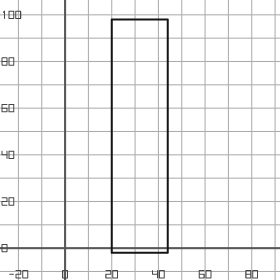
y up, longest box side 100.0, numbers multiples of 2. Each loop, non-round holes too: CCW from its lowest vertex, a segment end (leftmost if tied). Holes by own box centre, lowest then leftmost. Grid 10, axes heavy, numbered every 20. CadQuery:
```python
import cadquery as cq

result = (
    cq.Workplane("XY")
    .moveTo(20.0, -2.0)
    .lineTo(44.0, -2.0)
    .lineTo(44.0, 98.0)
    .lineTo(20.0, 98.0)
    .close()
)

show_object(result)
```